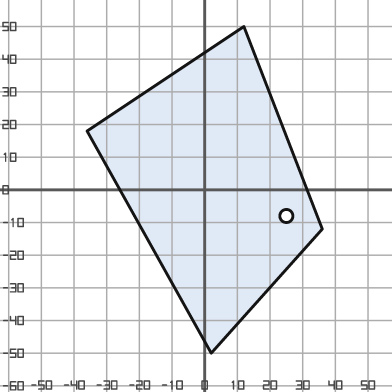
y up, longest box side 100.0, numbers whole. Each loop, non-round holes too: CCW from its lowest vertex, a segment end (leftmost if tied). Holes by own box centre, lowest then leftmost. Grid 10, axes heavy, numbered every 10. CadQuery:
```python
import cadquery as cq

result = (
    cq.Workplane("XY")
    .moveTo(2.0, -50.0)
    .lineTo(36.0, -12.0)
    .lineTo(12.0, 50.0)
    .lineTo(-36.0, 18.0)
    .close()
    .moveTo(25.0, -8.0)
    .circle(2.0)
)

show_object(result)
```